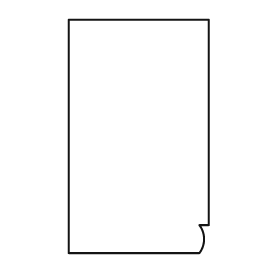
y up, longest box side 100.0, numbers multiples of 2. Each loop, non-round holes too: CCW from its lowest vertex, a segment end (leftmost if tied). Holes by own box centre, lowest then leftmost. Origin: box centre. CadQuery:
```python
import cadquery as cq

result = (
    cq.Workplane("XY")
    .moveTo(-30.0, -50.0)
    .lineTo(26.0, -50.0)
    .threePointArc((28.0, -44.0), (26.0, -38.0))
    .lineTo(30.0, -38.0)
    .lineTo(30.0, 50.0)
    .lineTo(-30.0, 50.0)
    .close()
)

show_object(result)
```